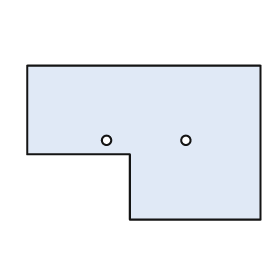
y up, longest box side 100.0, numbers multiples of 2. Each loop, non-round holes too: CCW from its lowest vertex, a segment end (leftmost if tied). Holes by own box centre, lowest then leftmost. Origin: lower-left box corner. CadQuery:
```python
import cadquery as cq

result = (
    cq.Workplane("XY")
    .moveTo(44.0, 0.0)
    .lineTo(100.0, 0.0)
    .lineTo(100.0, 66.0)
    .lineTo(0.0, 66.0)
    .lineTo(0.0, 28.0)
    .lineTo(44.0, 28.0)
    .close()
    .moveTo(34.0, 34.0)
    .circle(2.0)
    .moveTo(68.0, 34.0)
    .circle(2.0)
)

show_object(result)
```